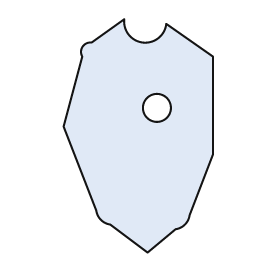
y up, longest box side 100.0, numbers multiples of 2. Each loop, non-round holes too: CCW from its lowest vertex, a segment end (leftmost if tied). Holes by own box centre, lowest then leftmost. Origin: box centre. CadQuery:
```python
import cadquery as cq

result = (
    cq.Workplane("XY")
    .moveTo(4.0, -50.0)
    .lineTo(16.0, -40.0)
    .threePointArc((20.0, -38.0), (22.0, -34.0))
    .lineTo(32.0, -8.0)
    .lineTo(32.0, 34.0)
    .lineTo(12.0, 48.0)
    .threePointArc((2.0, 40.0), (-6.0, 50.0))
    .lineTo(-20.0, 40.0)
    .threePointArc((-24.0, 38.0), (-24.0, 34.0))
    .lineTo(-32.0, 4.0)
    .lineTo(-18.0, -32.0)
    .threePointArc((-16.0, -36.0), (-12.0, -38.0))
    .close()
    .moveTo(8.0, 12.0)
    .circle(6.0)
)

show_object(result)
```